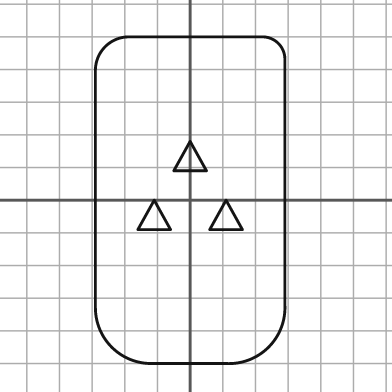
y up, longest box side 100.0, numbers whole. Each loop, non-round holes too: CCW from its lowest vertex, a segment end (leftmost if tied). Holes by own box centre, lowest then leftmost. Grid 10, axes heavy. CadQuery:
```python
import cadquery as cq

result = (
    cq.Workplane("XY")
    .moveTo(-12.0, -50.0)
    .lineTo(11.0, -50.0)
    .threePointArc((24.0, -45.0), (29.0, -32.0))
    .lineTo(29.0, 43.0)
    .threePointArc((27.0, 48.0), (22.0, 50.0))
    .lineTo(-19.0, 50.0)
    .threePointArc((-26.0, 47.0), (-29.0, 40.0))
    .lineTo(-29.0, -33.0)
    .threePointArc((-24.0, -45.0), (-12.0, -50.0))
    .close()
    .moveTo(-16.0, -9.0)
    .lineTo(-6.0, -9.0)
    .lineTo(-11.0, 0.0)
    .close()
    .moveTo(6.0, -9.0)
    .lineTo(16.0, -9.0)
    .lineTo(11.0, 0.0)
    .close()
    .moveTo(-5.0, 9.0)
    .lineTo(5.0, 9.0)
    .lineTo(0.0, 18.0)
    .close()
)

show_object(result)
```